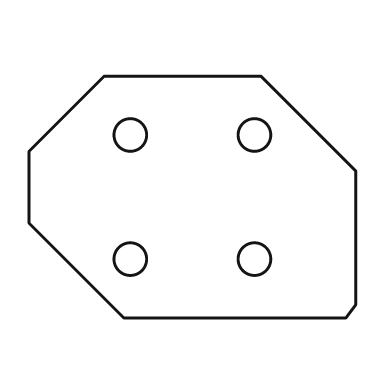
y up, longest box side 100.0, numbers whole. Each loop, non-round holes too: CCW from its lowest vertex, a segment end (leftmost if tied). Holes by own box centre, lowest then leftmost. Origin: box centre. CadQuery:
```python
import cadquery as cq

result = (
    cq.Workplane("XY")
    .moveTo(-21.0, -37.0)
    .lineTo(47.0, -37.0)
    .lineTo(50.0, -33.0)
    .lineTo(50.0, 8.0)
    .lineTo(21.0, 37.0)
    .lineTo(-27.0, 37.0)
    .lineTo(-50.0, 14.0)
    .lineTo(-50.0, -8.0)
    .close()
    .moveTo(-19.0, -19.0)
    .circle(5.0)
    .moveTo(19.0, -19.0)
    .circle(5.0)
    .moveTo(-19.0, 19.0)
    .circle(5.0)
    .moveTo(19.0, 19.0)
    .circle(5.0)
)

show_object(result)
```